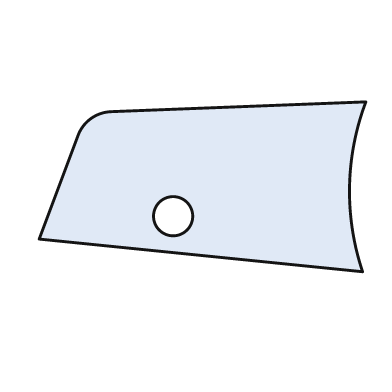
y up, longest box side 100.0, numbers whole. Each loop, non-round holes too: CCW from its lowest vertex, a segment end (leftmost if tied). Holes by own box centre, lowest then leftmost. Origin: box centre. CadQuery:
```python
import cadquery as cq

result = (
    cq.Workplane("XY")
    .moveTo(49.0, -26.0)
    .threePointArc((45.0, 0.0), (50.0, 26.0))
    .lineTo(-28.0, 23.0)
    .threePointArc((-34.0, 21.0), (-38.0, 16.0))
    .lineTo(-50.0, -16.0)
    .close()
    .moveTo(-9.0, -9.0)
    .circle(6.0)
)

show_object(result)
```